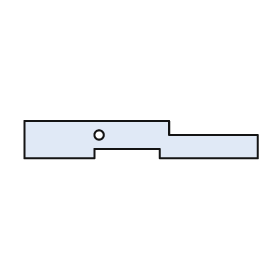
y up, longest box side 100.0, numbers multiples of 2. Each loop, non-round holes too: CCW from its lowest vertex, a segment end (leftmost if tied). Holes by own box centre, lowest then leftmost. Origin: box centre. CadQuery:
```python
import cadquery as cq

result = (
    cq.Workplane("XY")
    .moveTo(-50.0, -8.0)
    .lineTo(-20.0, -8.0)
    .lineTo(-20.0, -4.0)
    .lineTo(8.0, -4.0)
    .lineTo(8.0, -8.0)
    .lineTo(50.0, -8.0)
    .lineTo(50.0, 2.0)
    .lineTo(12.0, 2.0)
    .lineTo(12.0, 8.0)
    .lineTo(-50.0, 8.0)
    .close()
    .moveTo(-18.0, 2.0)
    .circle(2.0)
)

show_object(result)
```